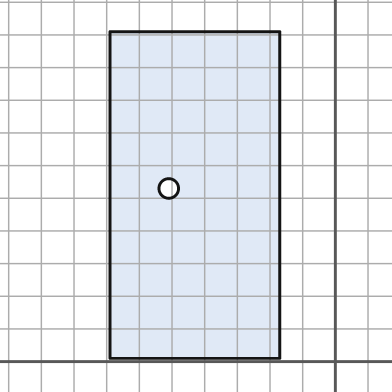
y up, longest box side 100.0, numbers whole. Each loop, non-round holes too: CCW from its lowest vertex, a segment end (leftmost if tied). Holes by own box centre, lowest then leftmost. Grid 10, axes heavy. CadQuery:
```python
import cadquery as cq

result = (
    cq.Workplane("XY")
    .moveTo(-69.0, 1.0)
    .lineTo(-17.0, 1.0)
    .lineTo(-17.0, 101.0)
    .lineTo(-69.0, 101.0)
    .close()
    .moveTo(-51.0, 53.0)
    .circle(3.0)
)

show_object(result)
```